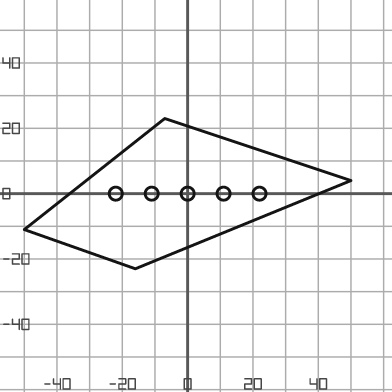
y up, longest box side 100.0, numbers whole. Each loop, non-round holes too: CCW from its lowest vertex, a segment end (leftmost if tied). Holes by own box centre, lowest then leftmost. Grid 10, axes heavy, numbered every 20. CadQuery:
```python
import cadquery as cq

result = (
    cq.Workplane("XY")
    .moveTo(-16.0, -23.0)
    .lineTo(50.0, 4.0)
    .lineTo(-7.0, 23.0)
    .lineTo(-50.0, -11.0)
    .close()
    .moveTo(-22.0, 0.0)
    .circle(2.0)
    .moveTo(-11.0, 0.0)
    .circle(2.0)
    .moveTo(0.0, 0.0)
    .circle(2.0)
    .moveTo(11.0, 0.0)
    .circle(2.0)
    .moveTo(22.0, 0.0)
    .circle(2.0)
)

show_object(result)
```